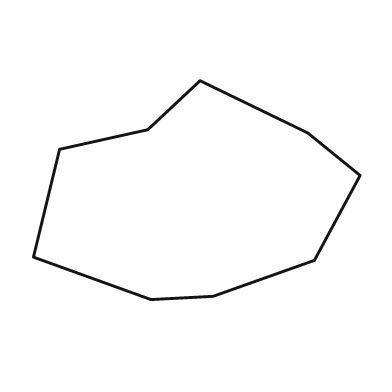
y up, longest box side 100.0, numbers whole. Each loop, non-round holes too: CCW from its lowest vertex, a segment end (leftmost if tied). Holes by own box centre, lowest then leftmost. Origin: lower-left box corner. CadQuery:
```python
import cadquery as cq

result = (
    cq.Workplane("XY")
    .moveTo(36.0, 0.0)
    .lineTo(55.0, 1.0)
    .lineTo(86.0, 12.0)
    .lineTo(100.0, 38.0)
    .lineTo(84.0, 51.0)
    .lineTo(51.0, 67.0)
    .lineTo(35.0, 52.0)
    .lineTo(8.0, 46.0)
    .lineTo(0.0, 13.0)
    .close()
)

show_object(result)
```